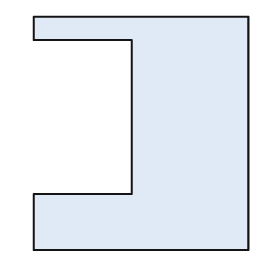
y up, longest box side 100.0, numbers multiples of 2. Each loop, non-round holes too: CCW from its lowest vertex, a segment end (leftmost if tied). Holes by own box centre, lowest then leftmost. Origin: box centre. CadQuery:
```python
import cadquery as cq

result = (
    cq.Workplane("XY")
    .moveTo(-46.0, -50.0)
    .lineTo(46.0, -50.0)
    .lineTo(46.0, 50.0)
    .lineTo(-46.0, 50.0)
    .lineTo(-46.0, 40.0)
    .lineTo(-4.0, 40.0)
    .lineTo(-4.0, -26.0)
    .lineTo(-46.0, -26.0)
    .close()
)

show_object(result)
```